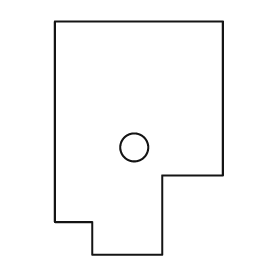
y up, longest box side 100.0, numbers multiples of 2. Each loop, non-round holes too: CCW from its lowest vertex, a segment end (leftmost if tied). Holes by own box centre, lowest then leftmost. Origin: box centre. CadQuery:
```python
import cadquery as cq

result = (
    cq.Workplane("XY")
    .moveTo(-20.0, -50.0)
    .lineTo(10.0, -50.0)
    .lineTo(10.0, -16.0)
    .lineTo(36.0, -16.0)
    .lineTo(36.0, 50.0)
    .lineTo(-36.0, 50.0)
    .lineTo(-36.0, -36.0)
    .lineTo(-20.0, -36.0)
    .close()
    .moveTo(-2.0, -4.0)
    .circle(6.0)
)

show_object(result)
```